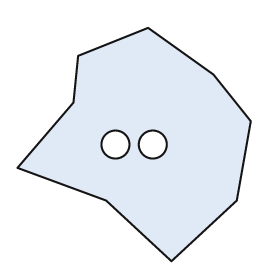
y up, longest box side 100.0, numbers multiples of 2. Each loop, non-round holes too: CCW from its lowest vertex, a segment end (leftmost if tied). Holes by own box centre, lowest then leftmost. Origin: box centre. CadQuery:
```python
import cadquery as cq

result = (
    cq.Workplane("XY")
    .moveTo(16.0, -50.0)
    .lineTo(44.0, -24.0)
    .lineTo(50.0, 10.0)
    .lineTo(34.0, 30.0)
    .lineTo(6.0, 50.0)
    .lineTo(-24.0, 38.0)
    .lineTo(-26.0, 18.0)
    .lineTo(-50.0, -10.0)
    .lineTo(-12.0, -24.0)
    .close()
    .moveTo(-8.0, 0.0)
    .circle(6.0)
    .moveTo(8.0, 0.0)
    .circle(6.0)
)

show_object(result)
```